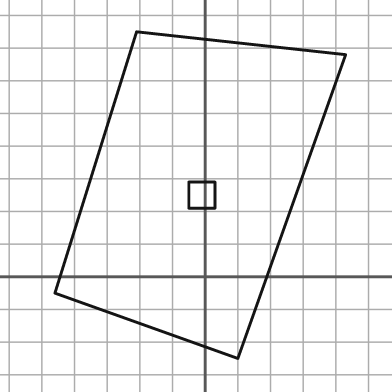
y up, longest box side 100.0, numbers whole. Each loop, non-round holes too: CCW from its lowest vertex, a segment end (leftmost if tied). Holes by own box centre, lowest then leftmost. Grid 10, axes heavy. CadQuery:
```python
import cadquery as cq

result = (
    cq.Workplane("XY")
    .moveTo(10.0, -25.0)
    .lineTo(43.0, 68.0)
    .lineTo(-21.0, 75.0)
    .lineTo(-46.0, -5.0)
    .close()
    .moveTo(-5.0, 21.0)
    .lineTo(3.0, 21.0)
    .lineTo(3.0, 29.0)
    .lineTo(-5.0, 29.0)
    .close()
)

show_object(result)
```